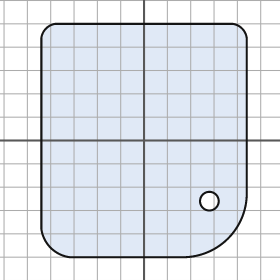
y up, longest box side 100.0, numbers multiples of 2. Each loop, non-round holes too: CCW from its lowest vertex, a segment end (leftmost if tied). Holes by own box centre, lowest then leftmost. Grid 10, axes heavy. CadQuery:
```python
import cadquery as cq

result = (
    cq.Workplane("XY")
    .moveTo(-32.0, -50.0)
    .lineTo(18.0, -50.0)
    .threePointArc((36.0, -42.0), (44.0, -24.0))
    .lineTo(44.0, 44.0)
    .threePointArc((42.0, 48.0), (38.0, 50.0))
    .lineTo(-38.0, 50.0)
    .threePointArc((-42.0, 48.0), (-44.0, 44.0))
    .lineTo(-44.0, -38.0)
    .threePointArc((-40.0, -46.0), (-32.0, -50.0))
    .close()
    .moveTo(28.0, -26.0)
    .circle(4.0)
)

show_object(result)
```